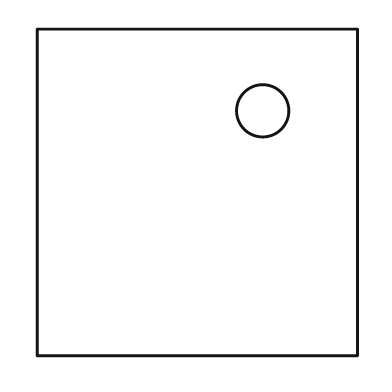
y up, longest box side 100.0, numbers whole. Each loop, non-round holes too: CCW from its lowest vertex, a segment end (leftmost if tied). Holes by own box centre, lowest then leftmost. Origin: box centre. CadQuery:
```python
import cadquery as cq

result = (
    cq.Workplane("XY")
    .moveTo(-49.0, -50.0)
    .lineTo(49.0, -50.0)
    .lineTo(49.0, 50.0)
    .lineTo(-49.0, 50.0)
    .close()
    .moveTo(20.0, 25.0)
    .circle(8.0)
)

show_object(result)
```